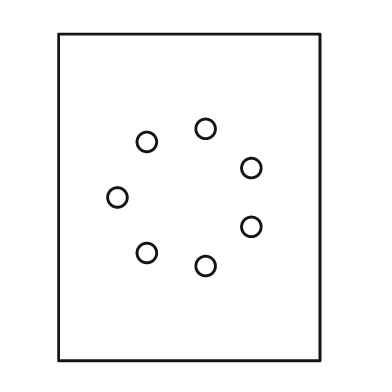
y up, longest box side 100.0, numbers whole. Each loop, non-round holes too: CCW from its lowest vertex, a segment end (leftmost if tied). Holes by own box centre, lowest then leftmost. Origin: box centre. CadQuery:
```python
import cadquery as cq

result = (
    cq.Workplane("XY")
    .moveTo(-40.0, -50.0)
    .lineTo(40.0, -50.0)
    .lineTo(40.0, 50.0)
    .lineTo(-40.0, 50.0)
    .close()
    .moveTo(5.0, -21.0)
    .circle(3.0)
    .moveTo(-13.0, -17.0)
    .circle(3.0)
    .moveTo(19.0, -9.0)
    .circle(3.0)
    .moveTo(-22.0, 0.0)
    .circle(3.0)
    .moveTo(19.0, 9.0)
    .circle(3.0)
    .moveTo(-13.0, 17.0)
    .circle(3.0)
    .moveTo(5.0, 21.0)
    .circle(3.0)
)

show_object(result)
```